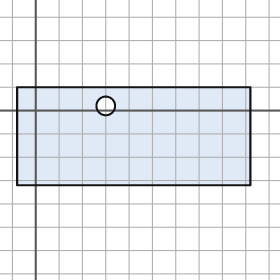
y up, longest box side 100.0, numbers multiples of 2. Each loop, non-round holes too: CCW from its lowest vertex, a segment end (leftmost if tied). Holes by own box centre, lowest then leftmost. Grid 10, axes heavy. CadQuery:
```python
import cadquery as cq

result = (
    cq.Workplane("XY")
    .moveTo(-8.0, -32.0)
    .lineTo(92.0, -32.0)
    .lineTo(92.0, 10.0)
    .lineTo(-8.0, 10.0)
    .close()
    .moveTo(30.0, 2.0)
    .circle(4.0)
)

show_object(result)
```